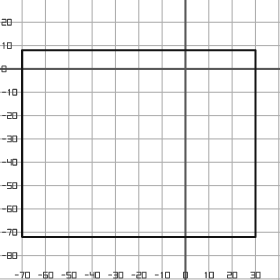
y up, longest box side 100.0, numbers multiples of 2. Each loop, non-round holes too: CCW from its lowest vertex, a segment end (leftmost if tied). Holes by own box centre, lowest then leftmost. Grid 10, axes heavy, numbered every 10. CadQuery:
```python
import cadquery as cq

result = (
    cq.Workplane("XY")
    .moveTo(-70.0, -72.0)
    .lineTo(30.0, -72.0)
    .lineTo(30.0, 8.0)
    .lineTo(-70.0, 8.0)
    .close()
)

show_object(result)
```